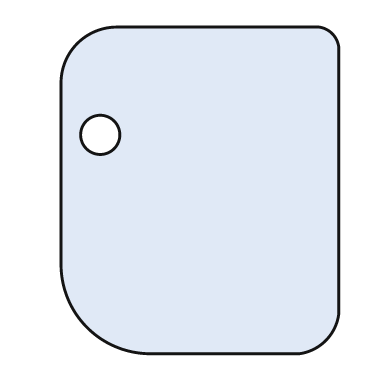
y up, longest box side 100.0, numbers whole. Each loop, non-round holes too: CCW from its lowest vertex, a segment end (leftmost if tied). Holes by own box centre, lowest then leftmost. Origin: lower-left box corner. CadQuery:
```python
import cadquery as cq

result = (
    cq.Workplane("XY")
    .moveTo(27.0, 0.0)
    .lineTo(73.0, 0.0)
    .threePointArc((81.0, 4.0), (85.0, 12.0))
    .lineTo(85.0, 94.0)
    .threePointArc((83.0, 98.0), (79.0, 100.0))
    .lineTo(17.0, 100.0)
    .threePointArc((5.0, 95.0), (0.0, 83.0))
    .lineTo(0.0, 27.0)
    .threePointArc((8.0, 8.0), (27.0, 0.0))
    .close()
    .moveTo(12.0, 67.0)
    .circle(6.0)
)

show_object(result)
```